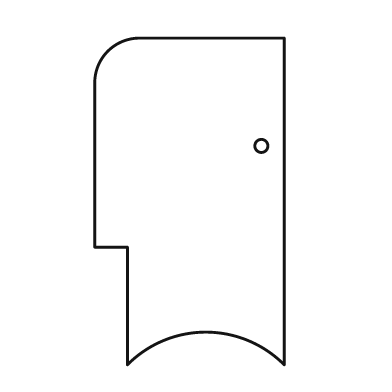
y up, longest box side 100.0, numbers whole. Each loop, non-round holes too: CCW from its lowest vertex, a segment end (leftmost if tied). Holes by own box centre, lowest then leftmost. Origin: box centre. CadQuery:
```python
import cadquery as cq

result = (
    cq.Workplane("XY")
    .moveTo(-19.0, -50.0)
    .threePointArc((5.0, -40.0), (29.0, -50.0))
    .lineTo(29.0, 50.0)
    .lineTo(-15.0, 50.0)
    .threePointArc((-25.0, 46.0), (-29.0, 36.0))
    .lineTo(-29.0, -14.0)
    .lineTo(-19.0, -14.0)
    .close()
    .moveTo(22.0, 17.0)
    .circle(2.0)
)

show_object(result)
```